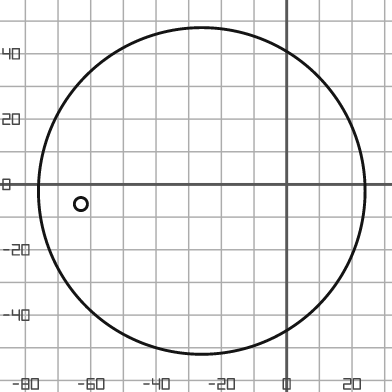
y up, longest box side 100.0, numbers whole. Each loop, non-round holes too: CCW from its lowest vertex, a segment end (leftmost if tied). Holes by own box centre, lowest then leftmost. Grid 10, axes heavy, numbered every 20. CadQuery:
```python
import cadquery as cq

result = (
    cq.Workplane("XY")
    .moveTo(-26.0, -2.0)
    .circle(50.0)
    .moveTo(-63.0, -6.0)
    .circle(2.0)
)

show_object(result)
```